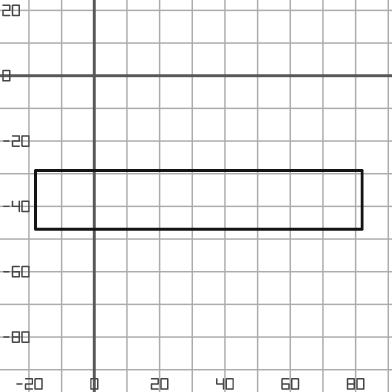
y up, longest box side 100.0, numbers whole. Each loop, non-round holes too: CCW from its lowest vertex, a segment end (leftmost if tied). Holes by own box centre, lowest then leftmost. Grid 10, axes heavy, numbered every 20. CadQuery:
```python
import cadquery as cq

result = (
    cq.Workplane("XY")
    .moveTo(-18.0, -47.0)
    .lineTo(82.0, -47.0)
    .lineTo(82.0, -29.0)
    .lineTo(-18.0, -29.0)
    .close()
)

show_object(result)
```